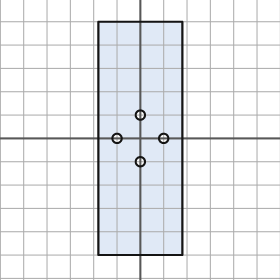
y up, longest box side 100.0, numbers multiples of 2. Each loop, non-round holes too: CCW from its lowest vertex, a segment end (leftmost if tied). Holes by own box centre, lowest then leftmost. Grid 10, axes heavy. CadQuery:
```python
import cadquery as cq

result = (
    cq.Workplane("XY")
    .moveTo(-18.0, -50.0)
    .lineTo(18.0, -50.0)
    .lineTo(18.0, 50.0)
    .lineTo(-18.0, 50.0)
    .close()
    .moveTo(0.0, -10.0)
    .circle(2.0)
    .moveTo(-10.0, 0.0)
    .circle(2.0)
    .moveTo(10.0, 0.0)
    .circle(2.0)
    .moveTo(0.0, 10.0)
    .circle(2.0)
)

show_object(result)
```